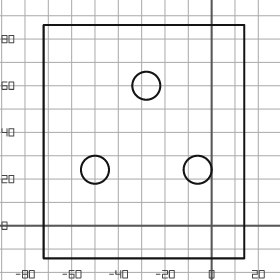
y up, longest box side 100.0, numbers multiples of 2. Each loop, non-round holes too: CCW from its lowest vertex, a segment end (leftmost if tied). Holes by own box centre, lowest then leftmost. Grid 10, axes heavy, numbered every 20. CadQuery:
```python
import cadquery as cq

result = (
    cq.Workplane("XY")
    .moveTo(-72.0, -14.0)
    .lineTo(14.0, -14.0)
    .lineTo(14.0, 86.0)
    .lineTo(-72.0, 86.0)
    .close()
    .moveTo(-50.0, 24.0)
    .circle(6.0)
    .moveTo(-6.0, 24.0)
    .circle(6.0)
    .moveTo(-28.0, 60.0)
    .circle(6.0)
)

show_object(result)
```